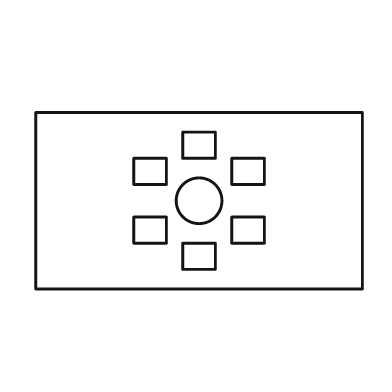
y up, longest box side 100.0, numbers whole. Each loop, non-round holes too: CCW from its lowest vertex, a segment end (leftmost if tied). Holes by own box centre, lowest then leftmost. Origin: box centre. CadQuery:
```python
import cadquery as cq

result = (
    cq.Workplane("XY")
    .moveTo(-50.0, -27.0)
    .lineTo(50.0, -27.0)
    .lineTo(50.0, 27.0)
    .lineTo(-50.0, 27.0)
    .close()
    .moveTo(-5.0, -21.0)
    .lineTo(5.0, -21.0)
    .lineTo(5.0, -13.0)
    .lineTo(-5.0, -13.0)
    .close()
    .moveTo(-20.0, -13.0)
    .lineTo(-10.0, -13.0)
    .lineTo(-10.0, -5.0)
    .lineTo(-20.0, -5.0)
    .close()
    .moveTo(10.0, -13.0)
    .lineTo(20.0, -13.0)
    .lineTo(20.0, -5.0)
    .lineTo(10.0, -5.0)
    .close()
    .moveTo(0.0, 0.0)
    .circle(7.0)
    .moveTo(-20.0, 5.0)
    .lineTo(-10.0, 5.0)
    .lineTo(-10.0, 13.0)
    .lineTo(-20.0, 13.0)
    .close()
    .moveTo(10.0, 5.0)
    .lineTo(20.0, 5.0)
    .lineTo(20.0, 13.0)
    .lineTo(10.0, 13.0)
    .close()
    .moveTo(-5.0, 13.0)
    .lineTo(5.0, 13.0)
    .lineTo(5.0, 21.0)
    .lineTo(-5.0, 21.0)
    .close()
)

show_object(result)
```